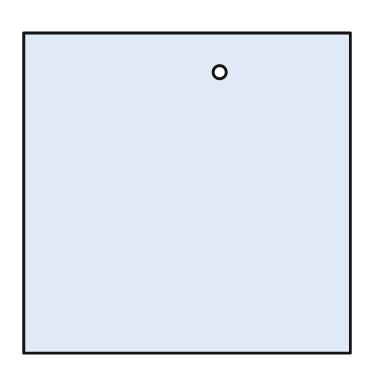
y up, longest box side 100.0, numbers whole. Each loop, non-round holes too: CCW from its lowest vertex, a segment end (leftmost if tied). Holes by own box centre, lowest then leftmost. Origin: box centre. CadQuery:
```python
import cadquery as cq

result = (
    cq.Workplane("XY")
    .moveTo(-50.0, -49.0)
    .lineTo(50.0, -49.0)
    .lineTo(50.0, 49.0)
    .lineTo(-50.0, 49.0)
    .close()
    .moveTo(10.0, 37.0)
    .circle(2.0)
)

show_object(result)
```